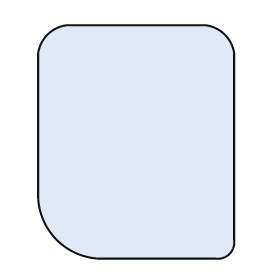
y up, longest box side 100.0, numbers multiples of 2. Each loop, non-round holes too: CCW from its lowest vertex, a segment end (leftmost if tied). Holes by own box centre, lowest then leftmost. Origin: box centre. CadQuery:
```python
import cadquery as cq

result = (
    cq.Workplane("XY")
    .moveTo(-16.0, -50.0)
    .lineTo(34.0, -50.0)
    .threePointArc((40.0, -48.0), (42.0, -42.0))
    .lineTo(42.0, 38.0)
    .threePointArc((38.0, 46.0), (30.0, 50.0))
    .lineTo(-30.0, 50.0)
    .threePointArc((-38.0, 46.0), (-42.0, 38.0))
    .lineTo(-42.0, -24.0)
    .threePointArc((-34.0, -42.0), (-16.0, -50.0))
    .close()
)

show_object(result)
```